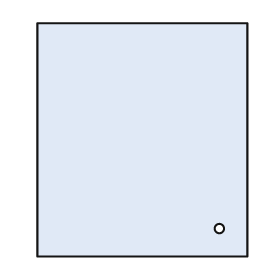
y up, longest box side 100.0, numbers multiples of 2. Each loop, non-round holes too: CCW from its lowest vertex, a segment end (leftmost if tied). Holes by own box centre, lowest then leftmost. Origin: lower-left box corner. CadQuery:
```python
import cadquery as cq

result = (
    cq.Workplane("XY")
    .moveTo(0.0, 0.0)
    .lineTo(90.0, 0.0)
    .lineTo(90.0, 100.0)
    .lineTo(0.0, 100.0)
    .close()
    .moveTo(78.0, 12.0)
    .circle(2.0)
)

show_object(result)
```